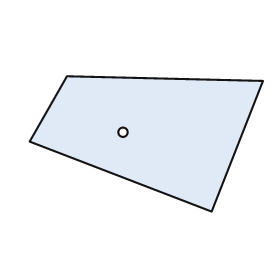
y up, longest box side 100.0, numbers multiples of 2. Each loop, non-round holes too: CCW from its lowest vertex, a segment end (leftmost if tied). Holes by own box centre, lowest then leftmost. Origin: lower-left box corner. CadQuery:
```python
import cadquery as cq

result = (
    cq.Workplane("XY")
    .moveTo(78.0, 0.0)
    .lineTo(100.0, 56.0)
    .lineTo(16.0, 58.0)
    .lineTo(0.0, 30.0)
    .close()
    .moveTo(40.0, 34.0)
    .circle(2.0)
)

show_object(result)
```